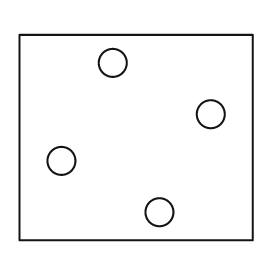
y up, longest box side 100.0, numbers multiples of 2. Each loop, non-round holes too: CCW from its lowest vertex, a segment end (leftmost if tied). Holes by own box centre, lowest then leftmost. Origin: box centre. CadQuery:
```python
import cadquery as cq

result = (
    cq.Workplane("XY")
    .moveTo(-50.0, -44.0)
    .lineTo(50.0, -44.0)
    .lineTo(50.0, 44.0)
    .lineTo(-50.0, 44.0)
    .close()
    .moveTo(10.0, -32.0)
    .circle(6.0)
    .moveTo(-32.0, -10.0)
    .circle(6.0)
    .moveTo(32.0, 10.0)
    .circle(6.0)
    .moveTo(-10.0, 32.0)
    .circle(6.0)
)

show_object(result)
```